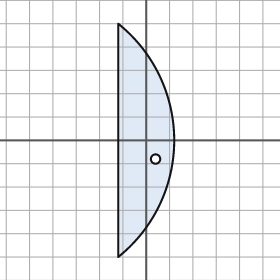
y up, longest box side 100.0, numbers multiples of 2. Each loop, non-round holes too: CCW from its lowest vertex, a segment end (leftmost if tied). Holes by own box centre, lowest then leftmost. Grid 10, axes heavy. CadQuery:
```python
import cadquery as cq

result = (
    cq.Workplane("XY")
    .moveTo(-12.0, -50.0)
    .threePointArc((12.0, 0.0), (-12.0, 50.0))
    .close()
    .moveTo(4.0, -8.0)
    .circle(2.0)
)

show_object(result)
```